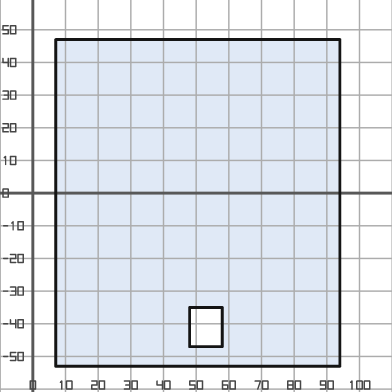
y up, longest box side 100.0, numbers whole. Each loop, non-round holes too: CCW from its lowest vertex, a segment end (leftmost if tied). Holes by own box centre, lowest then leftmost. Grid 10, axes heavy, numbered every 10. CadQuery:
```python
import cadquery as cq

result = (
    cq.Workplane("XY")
    .moveTo(7.0, -53.0)
    .lineTo(94.0, -53.0)
    .lineTo(94.0, 47.0)
    .lineTo(7.0, 47.0)
    .close()
    .moveTo(48.0, -47.0)
    .lineTo(58.0, -47.0)
    .lineTo(58.0, -35.0)
    .lineTo(48.0, -35.0)
    .close()
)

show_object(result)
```